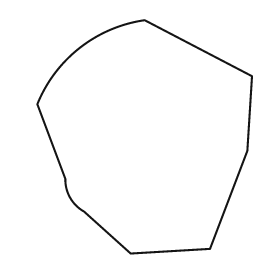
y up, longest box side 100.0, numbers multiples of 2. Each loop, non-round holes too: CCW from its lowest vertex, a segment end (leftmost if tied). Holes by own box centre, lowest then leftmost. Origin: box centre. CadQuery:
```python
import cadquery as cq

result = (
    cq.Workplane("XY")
    .moveTo(-6.0, -50.0)
    .lineTo(28.0, -48.0)
    .lineTo(44.0, -6.0)
    .lineTo(46.0, 26.0)
    .lineTo(0.0, 50.0)
    .threePointArc((-28.0, 38.0), (-46.0, 14.0))
    .lineTo(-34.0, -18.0)
    .threePointArc((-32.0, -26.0), (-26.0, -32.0))
    .close()
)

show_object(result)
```